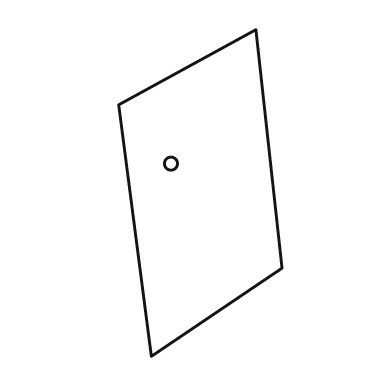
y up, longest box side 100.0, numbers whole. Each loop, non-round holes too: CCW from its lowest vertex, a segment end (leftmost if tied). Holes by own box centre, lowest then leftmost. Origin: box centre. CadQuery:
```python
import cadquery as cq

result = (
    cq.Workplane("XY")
    .moveTo(-15.0, -50.0)
    .lineTo(25.0, -23.0)
    .lineTo(17.0, 50.0)
    .lineTo(-25.0, 27.0)
    .close()
    .moveTo(-9.0, 9.0)
    .circle(2.0)
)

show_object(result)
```